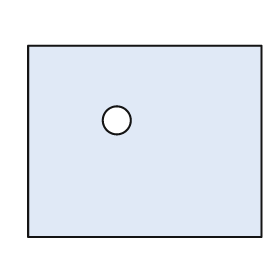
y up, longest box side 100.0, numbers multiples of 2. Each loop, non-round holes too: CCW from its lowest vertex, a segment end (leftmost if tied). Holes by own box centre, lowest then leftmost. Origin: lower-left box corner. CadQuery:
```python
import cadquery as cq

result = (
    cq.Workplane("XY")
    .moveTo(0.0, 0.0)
    .lineTo(100.0, 0.0)
    .lineTo(100.0, 82.0)
    .lineTo(0.0, 82.0)
    .close()
    .moveTo(38.0, 50.0)
    .circle(6.0)
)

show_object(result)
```